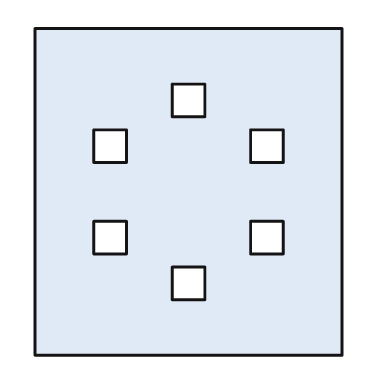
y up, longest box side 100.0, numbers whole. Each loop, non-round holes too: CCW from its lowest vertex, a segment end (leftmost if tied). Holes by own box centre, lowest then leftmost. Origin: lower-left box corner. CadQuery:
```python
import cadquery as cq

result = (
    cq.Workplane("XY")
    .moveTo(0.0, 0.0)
    .lineTo(94.0, 0.0)
    .lineTo(94.0, 100.0)
    .lineTo(0.0, 100.0)
    .close()
    .moveTo(42.0, 17.0)
    .lineTo(52.0, 17.0)
    .lineTo(52.0, 27.0)
    .lineTo(42.0, 27.0)
    .close()
    .moveTo(18.0, 31.0)
    .lineTo(28.0, 31.0)
    .lineTo(28.0, 41.0)
    .lineTo(18.0, 41.0)
    .close()
    .moveTo(66.0, 31.0)
    .lineTo(76.0, 31.0)
    .lineTo(76.0, 41.0)
    .lineTo(66.0, 41.0)
    .close()
    .moveTo(18.0, 59.0)
    .lineTo(28.0, 59.0)
    .lineTo(28.0, 69.0)
    .lineTo(18.0, 69.0)
    .close()
    .moveTo(66.0, 59.0)
    .lineTo(76.0, 59.0)
    .lineTo(76.0, 69.0)
    .lineTo(66.0, 69.0)
    .close()
    .moveTo(42.0, 73.0)
    .lineTo(52.0, 73.0)
    .lineTo(52.0, 83.0)
    .lineTo(42.0, 83.0)
    .close()
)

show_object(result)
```